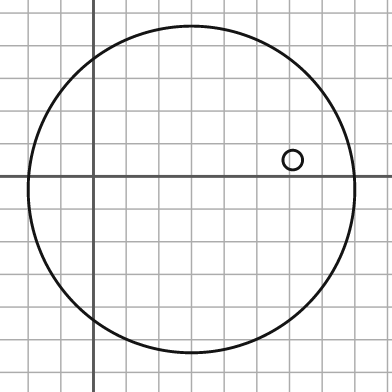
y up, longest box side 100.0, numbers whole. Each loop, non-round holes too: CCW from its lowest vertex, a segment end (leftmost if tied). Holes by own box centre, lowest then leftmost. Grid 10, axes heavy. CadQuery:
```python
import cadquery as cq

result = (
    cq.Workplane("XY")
    .moveTo(30.0, -4.0)
    .circle(50.0)
    .moveTo(61.0, 5.0)
    .circle(3.0)
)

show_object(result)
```